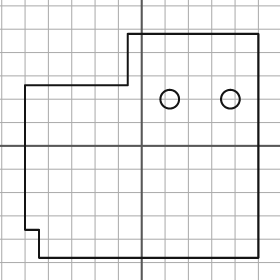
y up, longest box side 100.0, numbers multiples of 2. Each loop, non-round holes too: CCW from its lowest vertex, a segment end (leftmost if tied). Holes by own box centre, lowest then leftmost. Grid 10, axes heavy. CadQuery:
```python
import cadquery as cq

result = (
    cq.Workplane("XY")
    .moveTo(-44.0, -48.0)
    .lineTo(50.0, -48.0)
    .lineTo(50.0, 48.0)
    .lineTo(-6.0, 48.0)
    .lineTo(-6.0, 26.0)
    .lineTo(-50.0, 26.0)
    .lineTo(-50.0, -36.0)
    .lineTo(-44.0, -36.0)
    .close()
    .moveTo(12.0, 20.0)
    .circle(4.0)
    .moveTo(38.0, 20.0)
    .circle(4.0)
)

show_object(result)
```